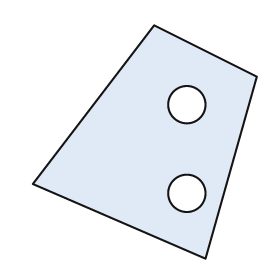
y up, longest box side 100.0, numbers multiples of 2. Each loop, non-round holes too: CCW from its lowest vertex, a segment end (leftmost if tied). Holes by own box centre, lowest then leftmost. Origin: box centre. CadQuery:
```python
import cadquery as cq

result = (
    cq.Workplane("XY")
    .moveTo(26.0, -50.0)
    .lineTo(48.0, 28.0)
    .lineTo(4.0, 50.0)
    .lineTo(-48.0, -18.0)
    .close()
    .moveTo(18.0, -22.0)
    .circle(8.0)
    .moveTo(18.0, 16.0)
    .circle(8.0)
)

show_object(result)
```